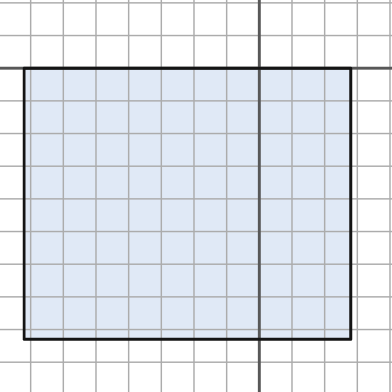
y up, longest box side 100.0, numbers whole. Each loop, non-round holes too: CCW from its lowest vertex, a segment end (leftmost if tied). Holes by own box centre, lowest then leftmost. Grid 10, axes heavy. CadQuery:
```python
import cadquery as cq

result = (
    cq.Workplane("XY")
    .moveTo(-72.0, -83.0)
    .lineTo(28.0, -83.0)
    .lineTo(28.0, 0.0)
    .lineTo(-72.0, 0.0)
    .close()
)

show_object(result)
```